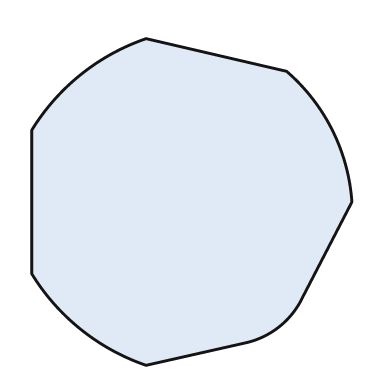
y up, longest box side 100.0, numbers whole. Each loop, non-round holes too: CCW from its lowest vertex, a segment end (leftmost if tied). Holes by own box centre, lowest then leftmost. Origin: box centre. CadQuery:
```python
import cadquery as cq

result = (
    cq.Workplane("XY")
    .moveTo(-14.0, -50.0)
    .lineTo(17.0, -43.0)
    .threePointArc((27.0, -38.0), (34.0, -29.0))
    .lineTo(49.0, 0.0)
    .threePointArc((43.0, 22.0), (29.0, 40.0))
    .lineTo(-14.0, 50.0)
    .threePointArc((-34.0, 39.0), (-49.0, 22.0))
    .lineTo(-49.0, -22.0)
    .threePointArc((-34.0, -39.0), (-14.0, -50.0))
    .close()
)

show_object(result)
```